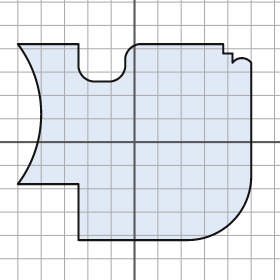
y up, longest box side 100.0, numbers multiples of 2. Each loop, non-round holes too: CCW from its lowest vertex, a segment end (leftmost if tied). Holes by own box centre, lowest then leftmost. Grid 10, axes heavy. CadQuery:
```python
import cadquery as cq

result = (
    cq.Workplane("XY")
    .moveTo(-24.0, -42.0)
    .lineTo(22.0, -42.0)
    .threePointArc((42.0, -34.0), (50.0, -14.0))
    .lineTo(50.0, 34.0)
    .threePointArc((46.0, 36.0), (42.0, 34.0))
    .lineTo(42.0, 38.0)
    .lineTo(38.0, 38.0)
    .lineTo(38.0, 42.0)
    .lineTo(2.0, 42.0)
    .threePointArc((-2.0, 40.0), (-4.0, 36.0))
    .lineTo(-4.0, 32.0)
    .threePointArc((-6.0, 28.0), (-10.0, 26.0))
    .lineTo(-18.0, 26.0)
    .threePointArc((-22.0, 28.0), (-24.0, 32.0))
    .lineTo(-24.0, 42.0)
    .lineTo(-50.0, 42.0)
    .threePointArc((-40.0, 12.0), (-50.0, -18.0))
    .lineTo(-24.0, -18.0)
    .close()
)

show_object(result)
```